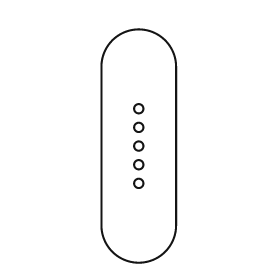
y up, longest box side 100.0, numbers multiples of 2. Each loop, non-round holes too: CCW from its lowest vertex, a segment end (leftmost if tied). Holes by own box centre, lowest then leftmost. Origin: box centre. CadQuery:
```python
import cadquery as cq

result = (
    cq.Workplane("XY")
    .moveTo(-16.0, -34.0)
    .threePointArc((0.0, -50.0), (16.0, -34.0))
    .lineTo(16.0, 34.0)
    .threePointArc((0.0, 50.0), (-16.0, 34.0))
    .close()
    .moveTo(0.0, -16.0)
    .circle(2.0)
    .moveTo(0.0, -8.0)
    .circle(2.0)
    .moveTo(0.0, 0.0)
    .circle(2.0)
    .moveTo(0.0, 8.0)
    .circle(2.0)
    .moveTo(0.0, 16.0)
    .circle(2.0)
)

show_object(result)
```